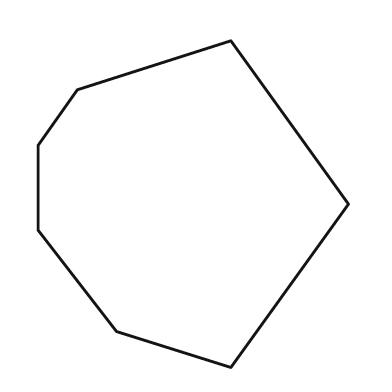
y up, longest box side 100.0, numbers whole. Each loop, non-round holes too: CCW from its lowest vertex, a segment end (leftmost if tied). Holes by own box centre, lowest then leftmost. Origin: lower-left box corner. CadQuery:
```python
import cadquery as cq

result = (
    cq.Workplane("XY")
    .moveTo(59.0, 0.0)
    .lineTo(95.0, 50.0)
    .lineTo(59.0, 100.0)
    .lineTo(12.0, 85.0)
    .lineTo(0.0, 68.0)
    .lineTo(0.0, 42.0)
    .lineTo(24.0, 11.0)
    .close()
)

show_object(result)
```